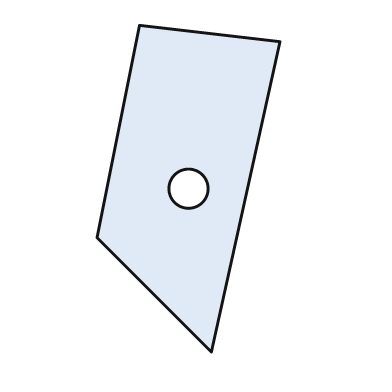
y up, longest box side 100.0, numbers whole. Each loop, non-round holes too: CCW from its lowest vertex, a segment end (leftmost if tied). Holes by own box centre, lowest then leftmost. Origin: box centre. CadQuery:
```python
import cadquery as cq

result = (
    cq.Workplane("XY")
    .moveTo(7.0, -50.0)
    .lineTo(28.0, 45.0)
    .lineTo(-15.0, 50.0)
    .lineTo(-28.0, -15.0)
    .close()
    .moveTo(0.0, 0.0)
    .circle(6.0)
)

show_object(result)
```